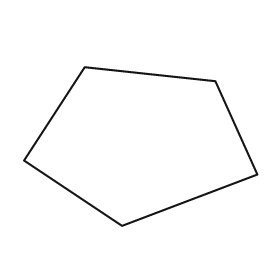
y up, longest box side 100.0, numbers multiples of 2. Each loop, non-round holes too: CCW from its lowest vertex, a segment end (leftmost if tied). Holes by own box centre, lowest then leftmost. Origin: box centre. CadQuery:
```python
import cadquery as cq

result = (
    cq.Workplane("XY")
    .moveTo(-8.0, -34.0)
    .lineTo(50.0, -12.0)
    .lineTo(32.0, 28.0)
    .lineTo(-24.0, 34.0)
    .lineTo(-50.0, -6.0)
    .close()
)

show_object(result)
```